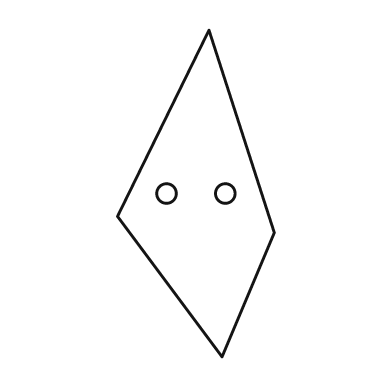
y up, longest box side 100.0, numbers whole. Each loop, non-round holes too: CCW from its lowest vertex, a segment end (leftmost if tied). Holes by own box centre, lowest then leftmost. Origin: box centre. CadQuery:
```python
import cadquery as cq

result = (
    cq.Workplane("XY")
    .moveTo(8.0, -50.0)
    .lineTo(24.0, -12.0)
    .lineTo(4.0, 50.0)
    .lineTo(-24.0, -7.0)
    .close()
    .moveTo(-9.0, 0.0)
    .circle(3.0)
    .moveTo(9.0, 0.0)
    .circle(3.0)
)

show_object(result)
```